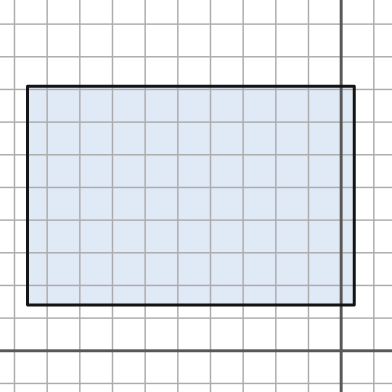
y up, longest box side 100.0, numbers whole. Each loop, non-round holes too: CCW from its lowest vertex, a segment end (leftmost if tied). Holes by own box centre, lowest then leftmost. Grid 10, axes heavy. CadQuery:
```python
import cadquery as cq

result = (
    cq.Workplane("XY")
    .moveTo(-96.0, 14.0)
    .lineTo(4.0, 14.0)
    .lineTo(4.0, 81.0)
    .lineTo(-96.0, 81.0)
    .close()
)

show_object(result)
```